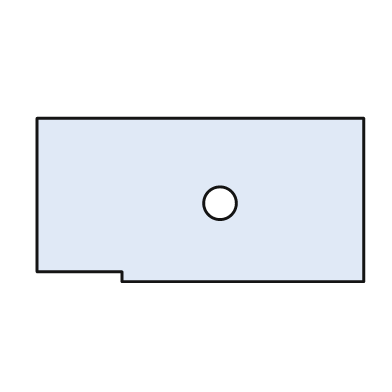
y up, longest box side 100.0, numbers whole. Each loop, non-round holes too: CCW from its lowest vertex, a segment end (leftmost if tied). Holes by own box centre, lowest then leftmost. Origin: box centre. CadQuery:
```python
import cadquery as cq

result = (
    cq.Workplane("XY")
    .moveTo(-24.0, -25.0)
    .lineTo(50.0, -25.0)
    .lineTo(50.0, 25.0)
    .lineTo(-50.0, 25.0)
    .lineTo(-50.0, -22.0)
    .lineTo(-24.0, -22.0)
    .close()
    .moveTo(6.0, -1.0)
    .circle(5.0)
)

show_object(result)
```